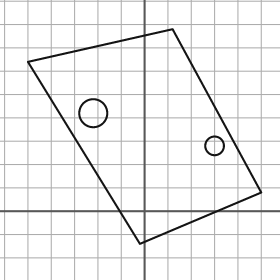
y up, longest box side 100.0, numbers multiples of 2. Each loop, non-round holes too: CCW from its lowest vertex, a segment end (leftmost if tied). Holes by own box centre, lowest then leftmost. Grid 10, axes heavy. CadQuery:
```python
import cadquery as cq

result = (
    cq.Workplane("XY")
    .moveTo(-2.0, -14.0)
    .lineTo(50.0, 8.0)
    .lineTo(12.0, 78.0)
    .lineTo(-50.0, 64.0)
    .close()
    .moveTo(30.0, 28.0)
    .circle(4.0)
    .moveTo(-22.0, 42.0)
    .circle(6.0)
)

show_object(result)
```